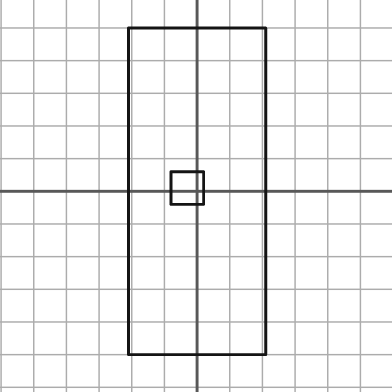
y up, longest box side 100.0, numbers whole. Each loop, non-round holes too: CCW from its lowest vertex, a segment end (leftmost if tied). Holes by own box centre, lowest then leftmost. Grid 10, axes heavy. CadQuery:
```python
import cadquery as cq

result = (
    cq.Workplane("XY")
    .moveTo(-21.0, -50.0)
    .lineTo(21.0, -50.0)
    .lineTo(21.0, 50.0)
    .lineTo(-21.0, 50.0)
    .close()
    .moveTo(-8.0, -4.0)
    .lineTo(2.0, -4.0)
    .lineTo(2.0, 6.0)
    .lineTo(-8.0, 6.0)
    .close()
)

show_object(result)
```